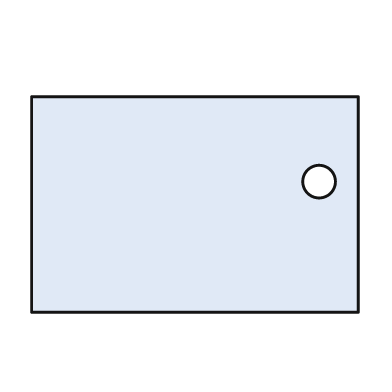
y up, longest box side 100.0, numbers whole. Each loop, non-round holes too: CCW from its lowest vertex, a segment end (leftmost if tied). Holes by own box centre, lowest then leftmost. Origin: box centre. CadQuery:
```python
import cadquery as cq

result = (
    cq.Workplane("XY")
    .moveTo(-50.0, -33.0)
    .lineTo(50.0, -33.0)
    .lineTo(50.0, 33.0)
    .lineTo(-50.0, 33.0)
    .close()
    .moveTo(38.0, 7.0)
    .circle(5.0)
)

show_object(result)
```